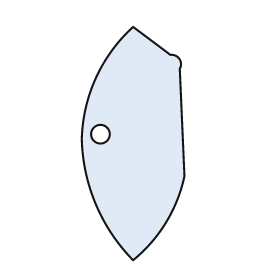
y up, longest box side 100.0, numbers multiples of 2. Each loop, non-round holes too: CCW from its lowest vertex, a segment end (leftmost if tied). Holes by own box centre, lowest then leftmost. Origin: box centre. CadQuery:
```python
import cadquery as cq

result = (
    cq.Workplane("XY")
    .moveTo(0.0, -50.0)
    .threePointArc((14.0, -34.0), (22.0, -14.0))
    .lineTo(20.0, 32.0)
    .threePointArc((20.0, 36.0), (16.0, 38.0))
    .lineTo(0.0, 50.0)
    .threePointArc((-16.0, 28.0), (-22.0, 2.0))
    .threePointArc((-16.0, -26.0), (0.0, -50.0))
    .close()
    .moveTo(-14.0, 4.0)
    .circle(4.0)
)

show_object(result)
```